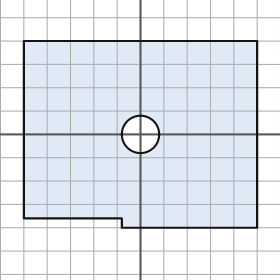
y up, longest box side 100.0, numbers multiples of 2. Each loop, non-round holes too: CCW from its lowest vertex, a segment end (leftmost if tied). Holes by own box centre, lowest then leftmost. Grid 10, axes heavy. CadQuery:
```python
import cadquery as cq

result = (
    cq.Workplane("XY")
    .moveTo(-8.0, -40.0)
    .lineTo(50.0, -40.0)
    .lineTo(50.0, 40.0)
    .lineTo(-50.0, 40.0)
    .lineTo(-50.0, -36.0)
    .lineTo(-8.0, -36.0)
    .close()
    .moveTo(0.0, 0.0)
    .circle(8.0)
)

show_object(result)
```